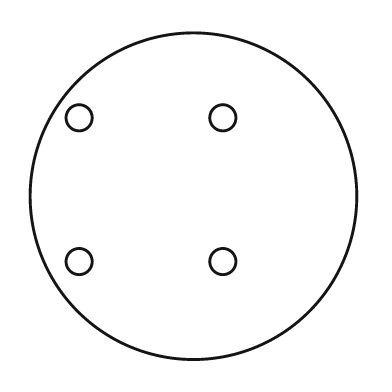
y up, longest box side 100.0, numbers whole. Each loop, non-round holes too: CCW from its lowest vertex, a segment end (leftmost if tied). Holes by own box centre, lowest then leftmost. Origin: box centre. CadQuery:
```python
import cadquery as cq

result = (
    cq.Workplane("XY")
    .moveTo(0.0, 0.0)
    .circle(50.0)
    .moveTo(-35.0, -20.0)
    .circle(4.0)
    .moveTo(9.0, -20.0)
    .circle(4.0)
    .moveTo(-35.0, 24.0)
    .circle(4.0)
    .moveTo(9.0, 24.0)
    .circle(4.0)
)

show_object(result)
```